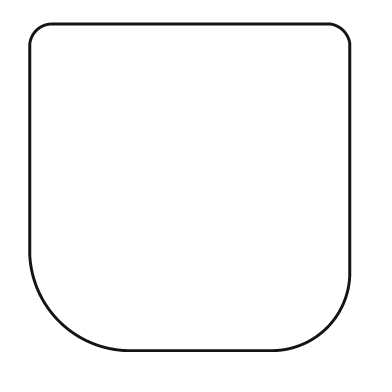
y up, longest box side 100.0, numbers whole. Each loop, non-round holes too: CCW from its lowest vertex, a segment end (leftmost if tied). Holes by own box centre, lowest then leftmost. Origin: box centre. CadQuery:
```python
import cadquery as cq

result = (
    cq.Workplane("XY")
    .moveTo(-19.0, -50.0)
    .lineTo(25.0, -50.0)
    .threePointArc((42.0, -43.0), (49.0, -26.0))
    .lineTo(49.0, 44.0)
    .threePointArc((47.0, 48.0), (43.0, 50.0))
    .lineTo(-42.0, 50.0)
    .threePointArc((-47.0, 48.0), (-49.0, 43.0))
    .lineTo(-49.0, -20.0)
    .threePointArc((-40.0, -41.0), (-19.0, -50.0))
    .close()
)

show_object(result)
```